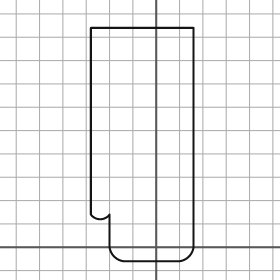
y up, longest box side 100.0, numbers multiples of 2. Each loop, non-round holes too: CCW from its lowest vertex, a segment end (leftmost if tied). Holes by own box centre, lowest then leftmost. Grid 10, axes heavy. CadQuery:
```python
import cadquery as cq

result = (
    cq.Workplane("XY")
    .moveTo(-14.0, -6.0)
    .lineTo(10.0, -6.0)
    .threePointArc((14.0, -4.0), (16.0, 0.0))
    .lineTo(16.0, 94.0)
    .lineTo(-28.0, 94.0)
    .lineTo(-28.0, 14.0)
    .threePointArc((-24.0, 12.0), (-20.0, 14.0))
    .lineTo(-20.0, 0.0)
    .threePointArc((-18.0, -4.0), (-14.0, -6.0))
    .close()
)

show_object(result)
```